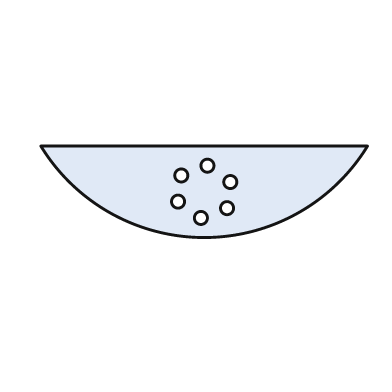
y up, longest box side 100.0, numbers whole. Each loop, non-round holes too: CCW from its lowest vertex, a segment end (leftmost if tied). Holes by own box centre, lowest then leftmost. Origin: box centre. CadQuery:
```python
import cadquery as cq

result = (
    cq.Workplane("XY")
    .moveTo(-50.0, 14.0)
    .threePointArc((0.0, -14.0), (50.0, 14.0))
    .close()
    .moveTo(-1.0, -8.0)
    .circle(2.0)
    .moveTo(7.0, -5.0)
    .circle(2.0)
    .moveTo(-8.0, -3.0)
    .circle(2.0)
    .moveTo(8.0, 3.0)
    .circle(2.0)
    .moveTo(-7.0, 5.0)
    .circle(2.0)
    .moveTo(1.0, 8.0)
    .circle(2.0)
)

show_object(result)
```